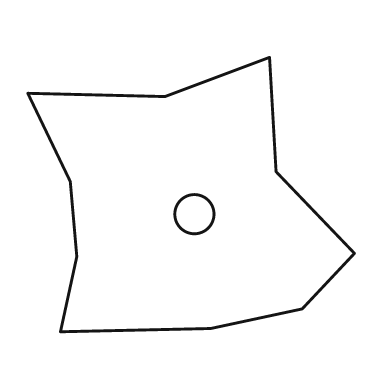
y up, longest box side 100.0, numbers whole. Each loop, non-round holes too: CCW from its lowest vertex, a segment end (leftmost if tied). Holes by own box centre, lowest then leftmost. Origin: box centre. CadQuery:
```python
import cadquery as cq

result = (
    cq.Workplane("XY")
    .moveTo(-40.0, -42.0)
    .lineTo(6.0, -41.0)
    .lineTo(34.0, -35.0)
    .lineTo(50.0, -18.0)
    .lineTo(26.0, 7.0)
    .lineTo(24.0, 42.0)
    .lineTo(-8.0, 30.0)
    .lineTo(-50.0, 31.0)
    .lineTo(-37.0, 4.0)
    .lineTo(-35.0, -19.0)
    .close()
    .moveTo(1.0, -6.0)
    .circle(6.0)
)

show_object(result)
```